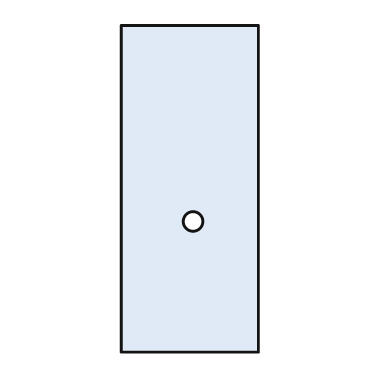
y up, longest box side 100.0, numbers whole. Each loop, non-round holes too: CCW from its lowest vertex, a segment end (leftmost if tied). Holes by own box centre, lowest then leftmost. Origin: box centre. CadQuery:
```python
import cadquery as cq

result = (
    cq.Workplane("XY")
    .moveTo(-21.0, -50.0)
    .lineTo(21.0, -50.0)
    .lineTo(21.0, 50.0)
    .lineTo(-21.0, 50.0)
    .close()
    .moveTo(1.0, -10.0)
    .circle(3.0)
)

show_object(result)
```